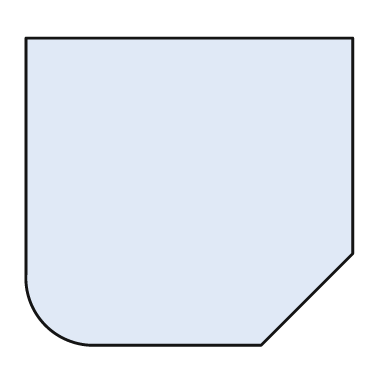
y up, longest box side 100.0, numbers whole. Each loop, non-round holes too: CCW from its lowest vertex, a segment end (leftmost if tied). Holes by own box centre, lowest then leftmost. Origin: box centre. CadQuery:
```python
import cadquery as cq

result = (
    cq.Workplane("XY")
    .moveTo(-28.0, -47.0)
    .lineTo(22.0, -47.0)
    .lineTo(50.0, -19.0)
    .lineTo(50.0, 47.0)
    .lineTo(-50.0, 47.0)
    .lineTo(-50.0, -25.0)
    .threePointArc((-44.0, -41.0), (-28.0, -47.0))
    .close()
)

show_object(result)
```